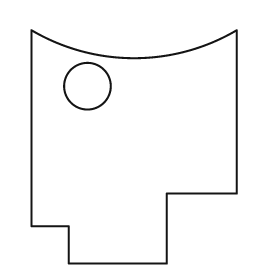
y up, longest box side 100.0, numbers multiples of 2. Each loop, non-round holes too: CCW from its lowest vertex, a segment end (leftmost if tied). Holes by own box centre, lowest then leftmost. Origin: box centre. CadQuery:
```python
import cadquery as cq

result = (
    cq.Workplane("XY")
    .moveTo(-28.0, -50.0)
    .lineTo(14.0, -50.0)
    .lineTo(14.0, -20.0)
    .lineTo(44.0, -20.0)
    .lineTo(44.0, 50.0)
    .threePointArc((0.0, 38.0), (-44.0, 50.0))
    .lineTo(-44.0, -34.0)
    .lineTo(-28.0, -34.0)
    .close()
    .moveTo(-20.0, 26.0)
    .circle(10.0)
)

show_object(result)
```